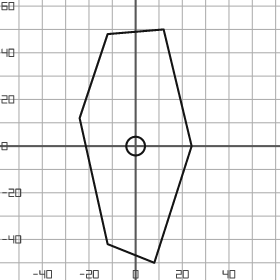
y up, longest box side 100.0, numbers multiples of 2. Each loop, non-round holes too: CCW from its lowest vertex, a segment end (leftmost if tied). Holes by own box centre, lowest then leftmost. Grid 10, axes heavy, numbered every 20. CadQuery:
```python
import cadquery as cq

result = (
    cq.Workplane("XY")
    .moveTo(8.0, -50.0)
    .lineTo(24.0, 0.0)
    .lineTo(12.0, 50.0)
    .lineTo(-12.0, 48.0)
    .lineTo(-24.0, 12.0)
    .lineTo(-12.0, -42.0)
    .close()
    .moveTo(0.0, 0.0)
    .circle(4.0)
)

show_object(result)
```